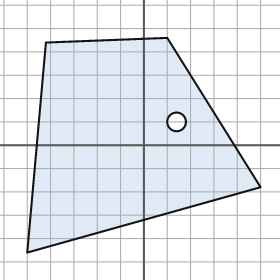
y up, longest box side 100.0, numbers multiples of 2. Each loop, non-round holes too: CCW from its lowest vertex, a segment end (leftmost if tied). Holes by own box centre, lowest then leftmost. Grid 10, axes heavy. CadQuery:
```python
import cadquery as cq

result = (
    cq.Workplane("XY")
    .moveTo(-50.0, -46.0)
    .lineTo(50.0, -18.0)
    .lineTo(10.0, 46.0)
    .lineTo(-42.0, 44.0)
    .close()
    .moveTo(14.0, 10.0)
    .circle(4.0)
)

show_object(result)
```